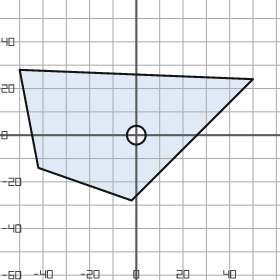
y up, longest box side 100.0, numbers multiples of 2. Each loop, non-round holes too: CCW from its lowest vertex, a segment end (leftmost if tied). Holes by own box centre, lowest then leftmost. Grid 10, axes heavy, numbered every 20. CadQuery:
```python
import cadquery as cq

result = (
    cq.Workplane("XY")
    .moveTo(-2.0, -28.0)
    .lineTo(50.0, 24.0)
    .lineTo(-50.0, 28.0)
    .lineTo(-42.0, -14.0)
    .close()
    .moveTo(0.0, 0.0)
    .circle(4.0)
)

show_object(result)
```